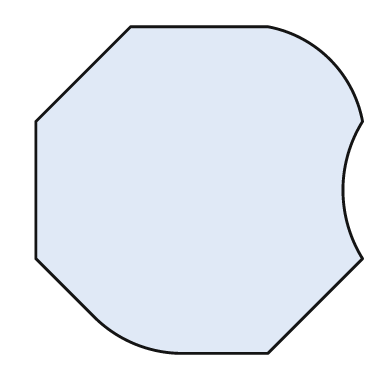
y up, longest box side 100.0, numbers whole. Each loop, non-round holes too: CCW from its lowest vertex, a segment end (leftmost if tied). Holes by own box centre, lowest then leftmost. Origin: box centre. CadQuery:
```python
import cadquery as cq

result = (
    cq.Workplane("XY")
    .moveTo(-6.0, -50.0)
    .lineTo(21.0, -50.0)
    .lineTo(50.0, -21.0)
    .threePointArc((44.0, 0.0), (50.0, 21.0))
    .threePointArc((40.0, 40.0), (21.0, 50.0))
    .lineTo(-21.0, 50.0)
    .lineTo(-50.0, 21.0)
    .lineTo(-50.0, -21.0)
    .lineTo(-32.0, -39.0)
    .threePointArc((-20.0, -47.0), (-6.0, -50.0))
    .close()
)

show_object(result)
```